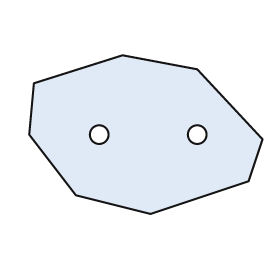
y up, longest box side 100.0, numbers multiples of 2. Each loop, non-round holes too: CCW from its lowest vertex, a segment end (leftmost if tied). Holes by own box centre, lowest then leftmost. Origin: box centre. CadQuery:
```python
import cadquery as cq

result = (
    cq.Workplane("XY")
    .moveTo(2.0, -34.0)
    .lineTo(44.0, -20.0)
    .lineTo(50.0, -2.0)
    .lineTo(22.0, 28.0)
    .lineTo(-10.0, 34.0)
    .lineTo(-48.0, 22.0)
    .lineTo(-50.0, 0.0)
    .lineTo(-30.0, -26.0)
    .close()
    .moveTo(-20.0, 0.0)
    .circle(4.0)
    .moveTo(22.0, 0.0)
    .circle(4.0)
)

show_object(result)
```